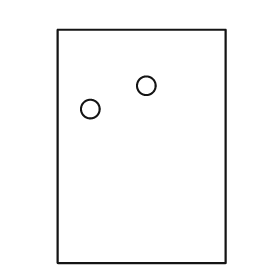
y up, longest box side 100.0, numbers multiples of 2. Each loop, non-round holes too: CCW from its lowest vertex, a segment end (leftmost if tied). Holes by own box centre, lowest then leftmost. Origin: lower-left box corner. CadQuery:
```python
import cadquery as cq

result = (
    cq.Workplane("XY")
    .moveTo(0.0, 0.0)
    .lineTo(72.0, 0.0)
    .lineTo(72.0, 100.0)
    .lineTo(0.0, 100.0)
    .close()
    .moveTo(14.0, 66.0)
    .circle(4.0)
    .moveTo(38.0, 76.0)
    .circle(4.0)
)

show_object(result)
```